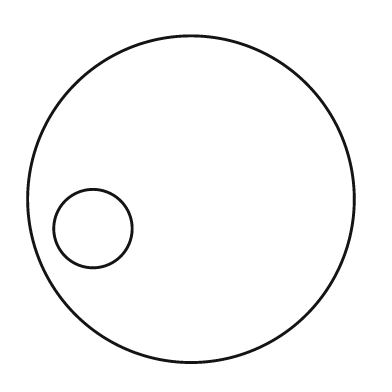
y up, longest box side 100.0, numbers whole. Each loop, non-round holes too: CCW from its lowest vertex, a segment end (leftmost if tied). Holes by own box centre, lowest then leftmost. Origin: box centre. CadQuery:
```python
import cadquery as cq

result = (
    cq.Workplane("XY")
    .moveTo(0.0, 0.0)
    .circle(50.0)
    .moveTo(-30.0, -9.0)
    .circle(12.0)
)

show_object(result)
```